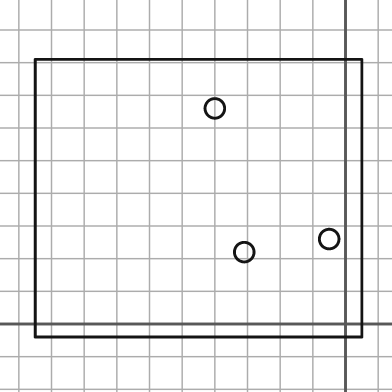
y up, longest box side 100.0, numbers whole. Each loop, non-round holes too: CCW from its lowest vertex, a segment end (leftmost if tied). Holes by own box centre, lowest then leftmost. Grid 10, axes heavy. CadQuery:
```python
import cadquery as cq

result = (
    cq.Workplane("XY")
    .moveTo(-95.0, -4.0)
    .lineTo(5.0, -4.0)
    .lineTo(5.0, 81.0)
    .lineTo(-95.0, 81.0)
    .close()
    .moveTo(-31.0, 22.0)
    .circle(3.0)
    .moveTo(-5.0, 26.0)
    .circle(3.0)
    .moveTo(-40.0, 66.0)
    .circle(3.0)
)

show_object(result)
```